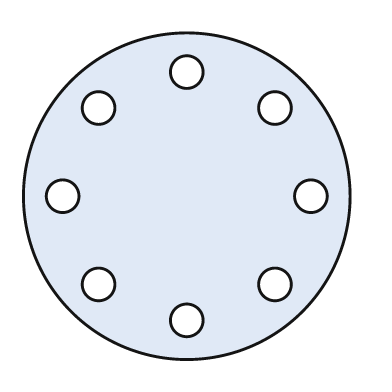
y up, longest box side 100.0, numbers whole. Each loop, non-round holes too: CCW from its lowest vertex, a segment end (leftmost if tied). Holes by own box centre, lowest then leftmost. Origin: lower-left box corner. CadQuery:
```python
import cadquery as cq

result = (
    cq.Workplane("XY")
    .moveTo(50.0, 50.0)
    .circle(50.0)
    .moveTo(50.0, 12.0)
    .circle(5.0)
    .moveTo(23.0, 23.0)
    .circle(5.0)
    .moveTo(77.0, 23.0)
    .circle(5.0)
    .moveTo(12.0, 50.0)
    .circle(5.0)
    .moveTo(88.0, 50.0)
    .circle(5.0)
    .moveTo(23.0, 77.0)
    .circle(5.0)
    .moveTo(77.0, 77.0)
    .circle(5.0)
    .moveTo(50.0, 88.0)
    .circle(5.0)
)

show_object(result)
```